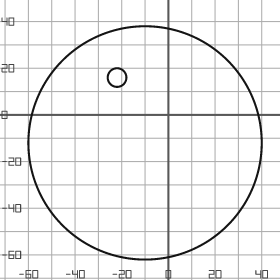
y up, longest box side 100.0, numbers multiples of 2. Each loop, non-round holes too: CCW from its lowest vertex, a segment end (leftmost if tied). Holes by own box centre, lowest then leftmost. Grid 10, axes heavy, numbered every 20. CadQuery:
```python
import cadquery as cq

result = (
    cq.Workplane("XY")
    .moveTo(-10.0, -12.0)
    .circle(50.0)
    .moveTo(-22.0, 16.0)
    .circle(4.0)
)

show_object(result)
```